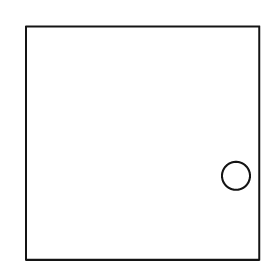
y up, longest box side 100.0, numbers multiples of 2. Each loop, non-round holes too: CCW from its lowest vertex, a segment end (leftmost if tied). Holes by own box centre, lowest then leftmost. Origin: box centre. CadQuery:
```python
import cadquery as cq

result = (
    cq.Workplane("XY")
    .moveTo(-50.0, -50.0)
    .lineTo(50.0, -50.0)
    .lineTo(50.0, 50.0)
    .lineTo(-50.0, 50.0)
    .close()
    .moveTo(40.0, -14.0)
    .circle(6.0)
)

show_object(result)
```